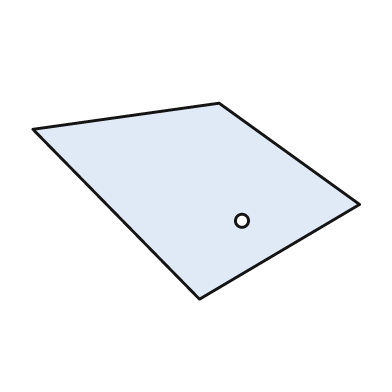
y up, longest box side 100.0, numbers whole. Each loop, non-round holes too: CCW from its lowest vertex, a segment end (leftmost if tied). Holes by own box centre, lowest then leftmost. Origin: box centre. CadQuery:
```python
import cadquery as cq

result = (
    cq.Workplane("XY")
    .moveTo(1.0, -30.0)
    .lineTo(50.0, -1.0)
    .lineTo(7.0, 30.0)
    .lineTo(-50.0, 22.0)
    .close()
    .moveTo(14.0, -6.0)
    .circle(2.0)
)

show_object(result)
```